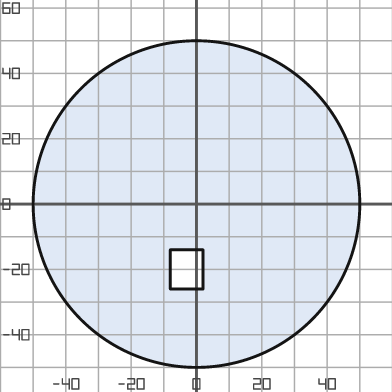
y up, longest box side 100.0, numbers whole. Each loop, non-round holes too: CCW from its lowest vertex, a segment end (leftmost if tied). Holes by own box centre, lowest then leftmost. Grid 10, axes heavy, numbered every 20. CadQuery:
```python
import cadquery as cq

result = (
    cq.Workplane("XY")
    .moveTo(0.0, 0.0)
    .circle(50.0)
    .moveTo(-8.0, -26.0)
    .lineTo(2.0, -26.0)
    .lineTo(2.0, -14.0)
    .lineTo(-8.0, -14.0)
    .close()
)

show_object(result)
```